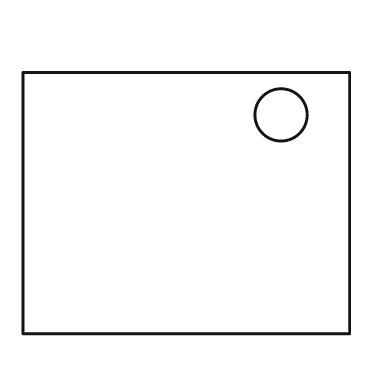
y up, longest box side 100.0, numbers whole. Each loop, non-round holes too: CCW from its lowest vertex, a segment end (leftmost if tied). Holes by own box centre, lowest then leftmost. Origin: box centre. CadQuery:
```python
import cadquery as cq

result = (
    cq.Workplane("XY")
    .moveTo(-50.0, -40.0)
    .lineTo(50.0, -40.0)
    .lineTo(50.0, 40.0)
    .lineTo(-50.0, 40.0)
    .close()
    .moveTo(29.0, 27.0)
    .circle(8.0)
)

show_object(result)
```